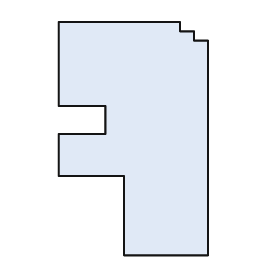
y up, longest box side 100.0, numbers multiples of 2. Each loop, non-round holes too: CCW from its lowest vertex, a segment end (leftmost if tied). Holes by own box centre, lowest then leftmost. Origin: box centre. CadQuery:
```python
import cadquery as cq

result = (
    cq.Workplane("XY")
    .moveTo(-4.0, -50.0)
    .lineTo(32.0, -50.0)
    .lineTo(32.0, 42.0)
    .lineTo(26.0, 42.0)
    .lineTo(26.0, 46.0)
    .lineTo(20.0, 46.0)
    .lineTo(20.0, 50.0)
    .lineTo(-32.0, 50.0)
    .lineTo(-32.0, 14.0)
    .lineTo(-12.0, 14.0)
    .lineTo(-12.0, 2.0)
    .lineTo(-32.0, 2.0)
    .lineTo(-32.0, -16.0)
    .lineTo(-4.0, -16.0)
    .close()
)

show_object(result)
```